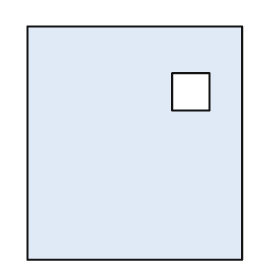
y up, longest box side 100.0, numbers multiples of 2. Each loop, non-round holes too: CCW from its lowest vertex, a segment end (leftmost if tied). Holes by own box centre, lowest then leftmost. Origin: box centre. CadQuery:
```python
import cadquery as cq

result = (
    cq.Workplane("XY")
    .moveTo(-46.0, -50.0)
    .lineTo(46.0, -50.0)
    .lineTo(46.0, 50.0)
    .lineTo(-46.0, 50.0)
    .close()
    .moveTo(16.0, 14.0)
    .lineTo(32.0, 14.0)
    .lineTo(32.0, 30.0)
    .lineTo(16.0, 30.0)
    .close()
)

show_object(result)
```